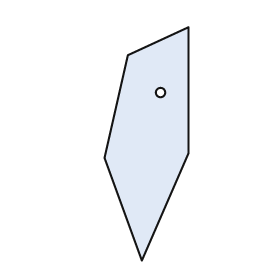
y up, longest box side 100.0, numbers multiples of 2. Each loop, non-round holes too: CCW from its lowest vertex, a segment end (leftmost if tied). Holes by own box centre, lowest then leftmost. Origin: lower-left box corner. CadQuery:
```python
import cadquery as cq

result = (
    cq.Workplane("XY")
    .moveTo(16.0, 0.0)
    .lineTo(36.0, 46.0)
    .lineTo(36.0, 100.0)
    .lineTo(10.0, 88.0)
    .lineTo(0.0, 44.0)
    .close()
    .moveTo(24.0, 72.0)
    .circle(2.0)
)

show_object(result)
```